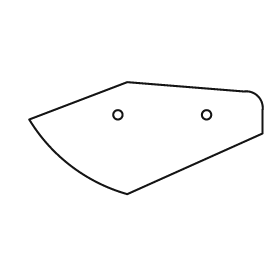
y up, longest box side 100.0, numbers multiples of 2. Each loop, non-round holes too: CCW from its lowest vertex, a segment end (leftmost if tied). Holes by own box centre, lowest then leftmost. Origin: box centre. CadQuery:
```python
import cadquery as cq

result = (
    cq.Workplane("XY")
    .moveTo(-8.0, -24.0)
    .lineTo(50.0, 2.0)
    .lineTo(50.0, 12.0)
    .threePointArc((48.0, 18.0), (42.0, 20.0))
    .lineTo(-8.0, 24.0)
    .lineTo(-50.0, 8.0)
    .threePointArc((-32.0, -12.0), (-8.0, -24.0))
    .close()
    .moveTo(-12.0, 10.0)
    .circle(2.0)
    .moveTo(26.0, 10.0)
    .circle(2.0)
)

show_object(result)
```